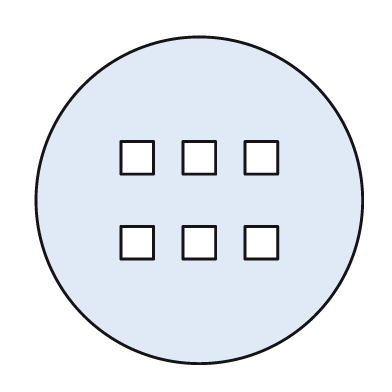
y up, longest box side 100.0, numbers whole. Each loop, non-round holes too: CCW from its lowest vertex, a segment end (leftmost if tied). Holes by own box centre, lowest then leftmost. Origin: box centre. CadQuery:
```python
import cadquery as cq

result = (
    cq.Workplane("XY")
    .moveTo(0.0, 0.0)
    .circle(50.0)
    .moveTo(-24.0, -18.0)
    .lineTo(-14.0, -18.0)
    .lineTo(-14.0, -8.0)
    .lineTo(-24.0, -8.0)
    .close()
    .moveTo(-5.0, -18.0)
    .lineTo(5.0, -18.0)
    .lineTo(5.0, -8.0)
    .lineTo(-5.0, -8.0)
    .close()
    .moveTo(14.0, -18.0)
    .lineTo(24.0, -18.0)
    .lineTo(24.0, -8.0)
    .lineTo(14.0, -8.0)
    .close()
    .moveTo(-24.0, 8.0)
    .lineTo(-14.0, 8.0)
    .lineTo(-14.0, 18.0)
    .lineTo(-24.0, 18.0)
    .close()
    .moveTo(-5.0, 8.0)
    .lineTo(5.0, 8.0)
    .lineTo(5.0, 18.0)
    .lineTo(-5.0, 18.0)
    .close()
    .moveTo(14.0, 8.0)
    .lineTo(24.0, 8.0)
    .lineTo(24.0, 18.0)
    .lineTo(14.0, 18.0)
    .close()
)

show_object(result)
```